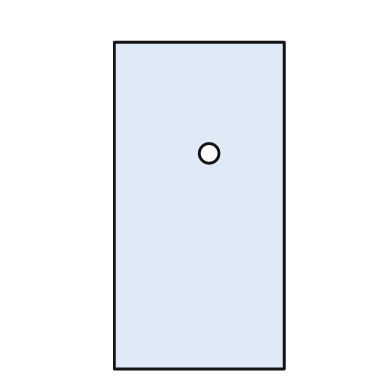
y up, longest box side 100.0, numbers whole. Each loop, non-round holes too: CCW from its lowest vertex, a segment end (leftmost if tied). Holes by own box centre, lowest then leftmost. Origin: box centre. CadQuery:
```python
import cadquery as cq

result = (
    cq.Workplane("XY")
    .moveTo(-26.0, -50.0)
    .lineTo(26.0, -50.0)
    .lineTo(26.0, 50.0)
    .lineTo(-26.0, 50.0)
    .close()
    .moveTo(3.0, 16.0)
    .circle(3.0)
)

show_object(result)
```